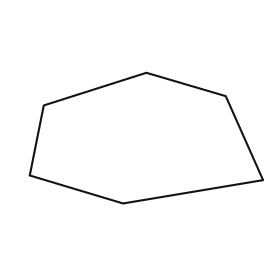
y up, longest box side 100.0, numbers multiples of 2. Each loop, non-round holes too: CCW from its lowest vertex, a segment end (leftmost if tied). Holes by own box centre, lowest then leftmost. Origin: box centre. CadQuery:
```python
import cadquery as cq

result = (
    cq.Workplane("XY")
    .moveTo(-10.0, -28.0)
    .lineTo(50.0, -18.0)
    .lineTo(34.0, 18.0)
    .lineTo(0.0, 28.0)
    .lineTo(-44.0, 14.0)
    .lineTo(-50.0, -16.0)
    .close()
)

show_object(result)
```